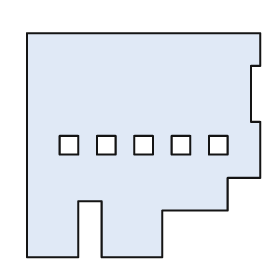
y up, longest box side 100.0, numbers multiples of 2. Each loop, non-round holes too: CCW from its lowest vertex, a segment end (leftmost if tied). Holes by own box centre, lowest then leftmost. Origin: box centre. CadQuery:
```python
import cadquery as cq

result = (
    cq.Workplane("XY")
    .moveTo(-50.0, -48.0)
    .lineTo(-28.0, -48.0)
    .lineTo(-28.0, -24.0)
    .lineTo(-18.0, -24.0)
    .lineTo(-18.0, -48.0)
    .lineTo(8.0, -48.0)
    .lineTo(8.0, -28.0)
    .lineTo(36.0, -28.0)
    .lineTo(36.0, -14.0)
    .lineTo(50.0, -14.0)
    .lineTo(50.0, 10.0)
    .lineTo(46.0, 10.0)
    .lineTo(46.0, 34.0)
    .lineTo(50.0, 34.0)
    .lineTo(50.0, 48.0)
    .lineTo(-50.0, 48.0)
    .close()
    .moveTo(-36.0, -4.0)
    .lineTo(-28.0, -4.0)
    .lineTo(-28.0, 4.0)
    .lineTo(-36.0, 4.0)
    .close()
    .moveTo(-20.0, -4.0)
    .lineTo(-12.0, -4.0)
    .lineTo(-12.0, 4.0)
    .lineTo(-20.0, 4.0)
    .close()
    .moveTo(-4.0, -4.0)
    .lineTo(4.0, -4.0)
    .lineTo(4.0, 4.0)
    .lineTo(-4.0, 4.0)
    .close()
    .moveTo(12.0, -4.0)
    .lineTo(20.0, -4.0)
    .lineTo(20.0, 4.0)
    .lineTo(12.0, 4.0)
    .close()
    .moveTo(28.0, -4.0)
    .lineTo(36.0, -4.0)
    .lineTo(36.0, 4.0)
    .lineTo(28.0, 4.0)
    .close()
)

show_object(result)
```